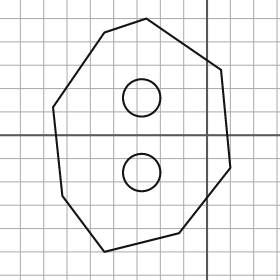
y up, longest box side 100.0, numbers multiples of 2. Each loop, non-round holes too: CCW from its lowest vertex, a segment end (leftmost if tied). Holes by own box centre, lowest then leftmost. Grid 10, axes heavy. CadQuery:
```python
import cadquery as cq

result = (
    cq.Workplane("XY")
    .moveTo(-44.0, -50.0)
    .lineTo(-12.0, -42.0)
    .lineTo(10.0, -14.0)
    .lineTo(6.0, 28.0)
    .lineTo(-26.0, 50.0)
    .lineTo(-44.0, 44.0)
    .lineTo(-66.0, 12.0)
    .lineTo(-62.0, -26.0)
    .close()
    .moveTo(-28.0, -16.0)
    .circle(8.0)
    .moveTo(-28.0, 16.0)
    .circle(8.0)
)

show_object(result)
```